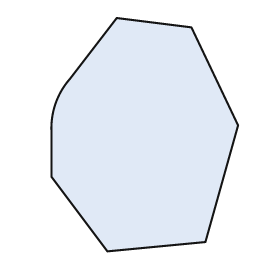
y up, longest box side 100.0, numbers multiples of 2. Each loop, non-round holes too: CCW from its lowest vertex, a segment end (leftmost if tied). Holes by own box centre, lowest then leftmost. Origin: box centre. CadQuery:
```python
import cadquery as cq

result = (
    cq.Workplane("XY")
    .moveTo(-16.0, -50.0)
    .lineTo(26.0, -46.0)
    .lineTo(40.0, 4.0)
    .lineTo(20.0, 46.0)
    .lineTo(-12.0, 50.0)
    .lineTo(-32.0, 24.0)
    .threePointArc((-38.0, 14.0), (-40.0, 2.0))
    .lineTo(-40.0, -18.0)
    .close()
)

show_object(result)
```